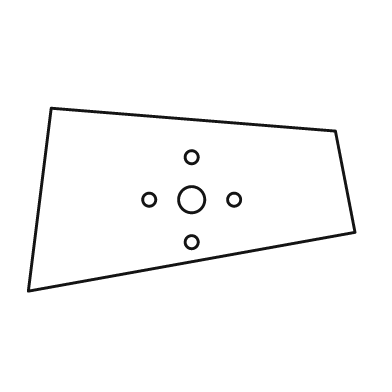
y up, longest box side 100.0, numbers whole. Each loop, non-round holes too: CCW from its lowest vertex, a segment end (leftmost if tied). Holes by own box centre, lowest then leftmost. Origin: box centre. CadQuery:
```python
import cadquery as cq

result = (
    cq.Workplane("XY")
    .moveTo(-50.0, -28.0)
    .lineTo(50.0, -10.0)
    .lineTo(44.0, 21.0)
    .lineTo(-43.0, 28.0)
    .close()
    .moveTo(0.0, -13.0)
    .circle(2.0)
    .moveTo(-13.0, 0.0)
    .circle(2.0)
    .moveTo(0.0, 0.0)
    .circle(4.0)
    .moveTo(13.0, 0.0)
    .circle(2.0)
    .moveTo(0.0, 13.0)
    .circle(2.0)
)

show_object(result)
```